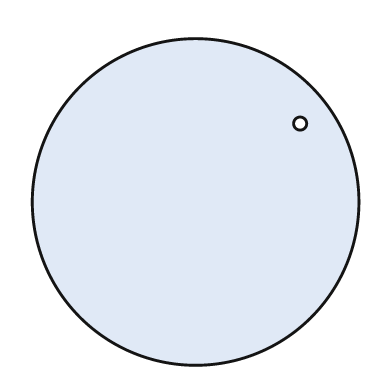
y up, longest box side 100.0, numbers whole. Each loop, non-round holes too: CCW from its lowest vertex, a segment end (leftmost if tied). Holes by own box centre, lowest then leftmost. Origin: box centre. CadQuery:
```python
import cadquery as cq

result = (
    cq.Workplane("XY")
    .moveTo(0.0, 0.0)
    .circle(50.0)
    .moveTo(32.0, 24.0)
    .circle(2.0)
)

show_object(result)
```